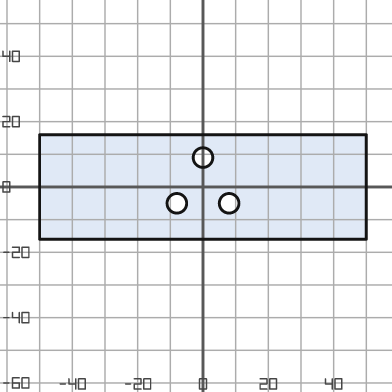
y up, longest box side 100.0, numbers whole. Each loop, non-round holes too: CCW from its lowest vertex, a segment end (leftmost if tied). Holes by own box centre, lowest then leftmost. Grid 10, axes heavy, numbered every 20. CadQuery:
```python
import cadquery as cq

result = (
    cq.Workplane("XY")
    .moveTo(-50.0, -16.0)
    .lineTo(50.0, -16.0)
    .lineTo(50.0, 16.0)
    .lineTo(-50.0, 16.0)
    .close()
    .moveTo(-8.0, -5.0)
    .circle(3.0)
    .moveTo(8.0, -5.0)
    .circle(3.0)
    .moveTo(0.0, 9.0)
    .circle(3.0)
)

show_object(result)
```